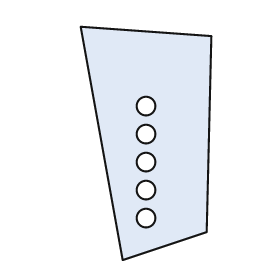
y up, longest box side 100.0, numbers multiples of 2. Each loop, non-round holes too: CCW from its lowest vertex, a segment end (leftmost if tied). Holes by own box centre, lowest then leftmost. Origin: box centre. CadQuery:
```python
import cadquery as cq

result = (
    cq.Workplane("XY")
    .moveTo(-10.0, -50.0)
    .lineTo(26.0, -38.0)
    .lineTo(28.0, 46.0)
    .lineTo(-28.0, 50.0)
    .close()
    .moveTo(0.0, -32.0)
    .circle(4.0)
    .moveTo(0.0, -20.0)
    .circle(4.0)
    .moveTo(0.0, -8.0)
    .circle(4.0)
    .moveTo(0.0, 4.0)
    .circle(4.0)
    .moveTo(0.0, 16.0)
    .circle(4.0)
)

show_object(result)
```